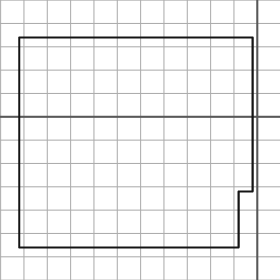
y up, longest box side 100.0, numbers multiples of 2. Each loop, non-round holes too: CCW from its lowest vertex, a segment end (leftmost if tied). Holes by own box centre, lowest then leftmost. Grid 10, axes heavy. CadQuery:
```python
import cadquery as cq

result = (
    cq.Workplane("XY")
    .moveTo(-102.0, -56.0)
    .lineTo(-8.0, -56.0)
    .lineTo(-8.0, -32.0)
    .lineTo(-2.0, -32.0)
    .lineTo(-2.0, 34.0)
    .lineTo(-102.0, 34.0)
    .close()
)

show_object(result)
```